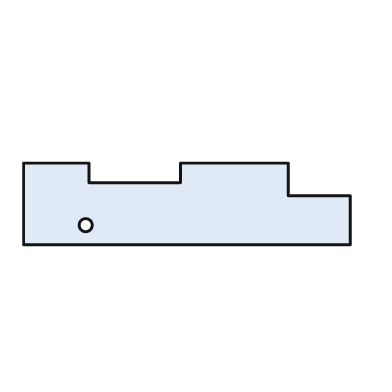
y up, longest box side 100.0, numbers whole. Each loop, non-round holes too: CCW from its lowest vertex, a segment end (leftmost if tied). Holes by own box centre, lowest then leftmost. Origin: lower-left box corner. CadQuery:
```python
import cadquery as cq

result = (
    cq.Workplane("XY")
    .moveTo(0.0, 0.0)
    .lineTo(100.0, 0.0)
    .lineTo(100.0, 15.0)
    .lineTo(81.0, 15.0)
    .lineTo(81.0, 25.0)
    .lineTo(48.0, 25.0)
    .lineTo(48.0, 19.0)
    .lineTo(20.0, 19.0)
    .lineTo(20.0, 25.0)
    .lineTo(0.0, 25.0)
    .close()
    .moveTo(19.0, 6.0)
    .circle(2.0)
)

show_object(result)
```